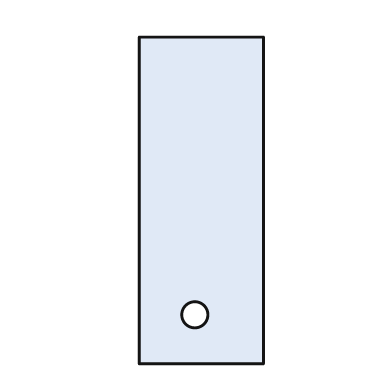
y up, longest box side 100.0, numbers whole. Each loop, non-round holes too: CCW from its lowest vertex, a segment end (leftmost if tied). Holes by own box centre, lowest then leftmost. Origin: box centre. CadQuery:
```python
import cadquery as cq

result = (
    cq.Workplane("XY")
    .moveTo(-19.0, -50.0)
    .lineTo(19.0, -50.0)
    .lineTo(19.0, 50.0)
    .lineTo(-19.0, 50.0)
    .close()
    .moveTo(-2.0, -35.0)
    .circle(4.0)
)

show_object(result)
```